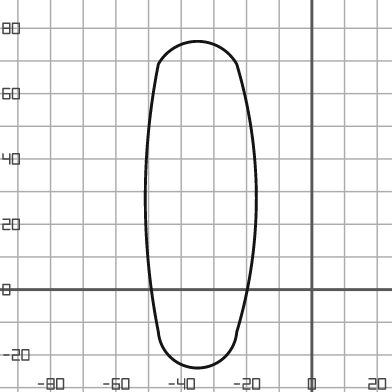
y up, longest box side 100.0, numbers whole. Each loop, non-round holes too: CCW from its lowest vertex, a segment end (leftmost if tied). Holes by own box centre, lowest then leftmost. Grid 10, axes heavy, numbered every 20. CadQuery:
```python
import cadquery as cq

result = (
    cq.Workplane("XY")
    .moveTo(-47.0, -13.0)
    .threePointArc((-35.0, -24.0), (-23.0, -13.0))
    .threePointArc((-17.0, 28.0), (-23.0, 69.0))
    .threePointArc((-35.0, 76.0), (-47.0, 69.0))
    .threePointArc((-51.0, 28.0), (-47.0, -13.0))
    .close()
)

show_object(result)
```